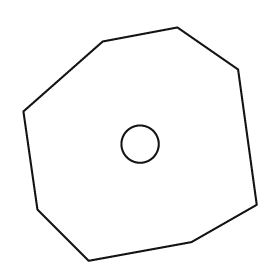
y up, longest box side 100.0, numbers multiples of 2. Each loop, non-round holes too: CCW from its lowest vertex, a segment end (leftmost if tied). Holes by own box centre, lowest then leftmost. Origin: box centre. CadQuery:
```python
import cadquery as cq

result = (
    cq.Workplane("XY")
    .moveTo(-22.0, -50.0)
    .lineTo(22.0, -42.0)
    .lineTo(50.0, -26.0)
    .lineTo(42.0, 32.0)
    .lineTo(16.0, 50.0)
    .lineTo(-16.0, 44.0)
    .lineTo(-50.0, 14.0)
    .lineTo(-44.0, -28.0)
    .close()
    .moveTo(0.0, 0.0)
    .circle(8.0)
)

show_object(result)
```